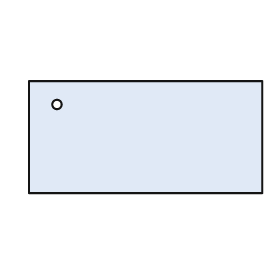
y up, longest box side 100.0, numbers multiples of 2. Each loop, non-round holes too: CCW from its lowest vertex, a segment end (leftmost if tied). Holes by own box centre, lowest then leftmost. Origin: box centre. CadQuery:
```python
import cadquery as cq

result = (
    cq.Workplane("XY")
    .moveTo(-50.0, -24.0)
    .lineTo(50.0, -24.0)
    .lineTo(50.0, 24.0)
    .lineTo(-50.0, 24.0)
    .close()
    .moveTo(-38.0, 14.0)
    .circle(2.0)
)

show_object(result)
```